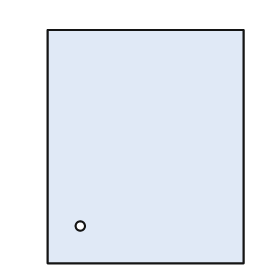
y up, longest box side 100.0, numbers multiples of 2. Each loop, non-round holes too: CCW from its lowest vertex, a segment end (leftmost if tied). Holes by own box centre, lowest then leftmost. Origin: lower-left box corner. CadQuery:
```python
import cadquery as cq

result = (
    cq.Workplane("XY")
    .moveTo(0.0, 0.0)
    .lineTo(84.0, 0.0)
    .lineTo(84.0, 100.0)
    .lineTo(0.0, 100.0)
    .close()
    .moveTo(14.0, 16.0)
    .circle(2.0)
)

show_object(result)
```